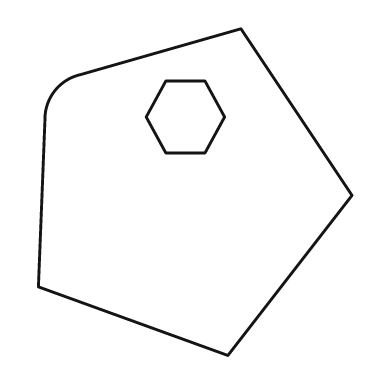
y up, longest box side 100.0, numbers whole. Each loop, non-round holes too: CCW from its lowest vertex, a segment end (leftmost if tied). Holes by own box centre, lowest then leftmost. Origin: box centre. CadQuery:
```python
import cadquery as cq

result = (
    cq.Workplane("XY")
    .moveTo(10.0, -50.0)
    .lineTo(48.0, -1.0)
    .lineTo(14.0, 50.0)
    .lineTo(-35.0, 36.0)
    .threePointArc((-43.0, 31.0), (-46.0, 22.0))
    .lineTo(-48.0, -29.0)
    .close()
    .moveTo(-9.0, 12.0)
    .lineTo(3.0, 12.0)
    .lineTo(9.0, 23.0)
    .lineTo(3.0, 34.0)
    .lineTo(-9.0, 34.0)
    .lineTo(-15.0, 23.0)
    .close()
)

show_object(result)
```